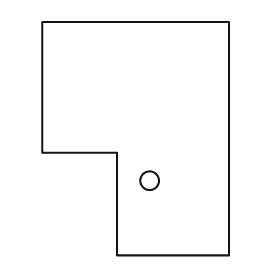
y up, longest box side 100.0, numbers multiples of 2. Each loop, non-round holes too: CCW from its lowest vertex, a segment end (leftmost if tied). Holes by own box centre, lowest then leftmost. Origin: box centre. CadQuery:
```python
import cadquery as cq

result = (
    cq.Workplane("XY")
    .moveTo(-8.0, -50.0)
    .lineTo(40.0, -50.0)
    .lineTo(40.0, 50.0)
    .lineTo(-40.0, 50.0)
    .lineTo(-40.0, -6.0)
    .lineTo(-8.0, -6.0)
    .close()
    .moveTo(6.0, -18.0)
    .circle(4.0)
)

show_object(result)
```